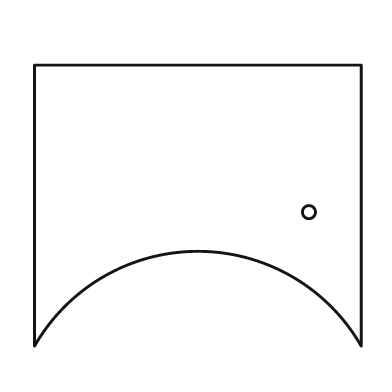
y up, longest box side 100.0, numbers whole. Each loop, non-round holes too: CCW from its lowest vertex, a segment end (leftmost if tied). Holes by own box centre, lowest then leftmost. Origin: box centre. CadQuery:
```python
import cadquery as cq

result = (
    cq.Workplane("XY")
    .moveTo(-50.0, -43.0)
    .threePointArc((0.0, -14.0), (50.0, -43.0))
    .lineTo(50.0, 43.0)
    .lineTo(-50.0, 43.0)
    .close()
    .moveTo(34.0, -2.0)
    .circle(2.0)
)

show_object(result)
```